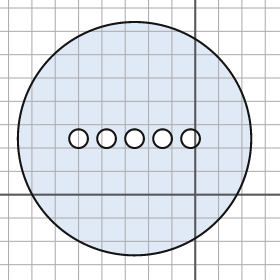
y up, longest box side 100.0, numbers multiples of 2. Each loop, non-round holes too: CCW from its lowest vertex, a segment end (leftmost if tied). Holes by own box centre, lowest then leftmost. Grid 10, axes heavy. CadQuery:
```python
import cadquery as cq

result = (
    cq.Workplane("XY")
    .moveTo(-26.0, 24.0)
    .circle(50.0)
    .moveTo(-50.0, 24.0)
    .circle(4.0)
    .moveTo(-38.0, 24.0)
    .circle(4.0)
    .moveTo(-26.0, 24.0)
    .circle(4.0)
    .moveTo(-14.0, 24.0)
    .circle(4.0)
    .moveTo(-2.0, 24.0)
    .circle(4.0)
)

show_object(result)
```